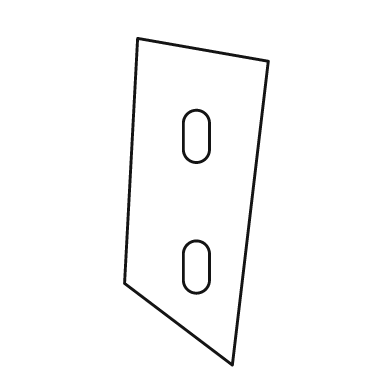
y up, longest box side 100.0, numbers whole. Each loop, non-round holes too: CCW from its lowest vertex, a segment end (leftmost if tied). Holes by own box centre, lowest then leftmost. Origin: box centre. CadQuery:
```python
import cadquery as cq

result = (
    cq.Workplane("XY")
    .moveTo(11.0, -50.0)
    .lineTo(22.0, 43.0)
    .lineTo(-18.0, 50.0)
    .lineTo(-22.0, -25.0)
    .close()
    .moveTo(-4.0, -24.0)
    .threePointArc((0.0, -28.0), (4.0, -24.0))
    .lineTo(4.0, -16.0)
    .threePointArc((0.0, -12.0), (-4.0, -16.0))
    .close()
    .moveTo(-4.0, 16.0)
    .threePointArc((0.0, 12.0), (4.0, 16.0))
    .lineTo(4.0, 24.0)
    .threePointArc((0.0, 28.0), (-4.0, 24.0))
    .close()
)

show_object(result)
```